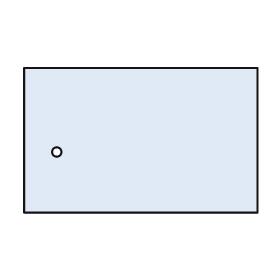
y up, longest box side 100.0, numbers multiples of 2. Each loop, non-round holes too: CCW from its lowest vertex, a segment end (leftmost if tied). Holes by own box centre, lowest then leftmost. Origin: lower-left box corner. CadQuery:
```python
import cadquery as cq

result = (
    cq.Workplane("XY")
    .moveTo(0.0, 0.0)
    .lineTo(100.0, 0.0)
    .lineTo(100.0, 62.0)
    .lineTo(0.0, 62.0)
    .close()
    .moveTo(14.0, 26.0)
    .circle(2.0)
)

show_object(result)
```